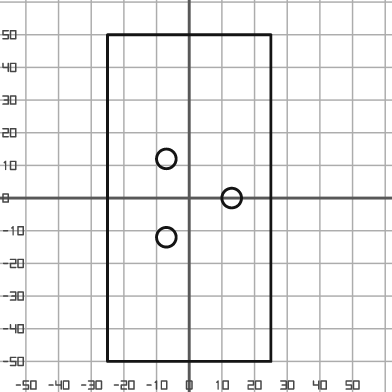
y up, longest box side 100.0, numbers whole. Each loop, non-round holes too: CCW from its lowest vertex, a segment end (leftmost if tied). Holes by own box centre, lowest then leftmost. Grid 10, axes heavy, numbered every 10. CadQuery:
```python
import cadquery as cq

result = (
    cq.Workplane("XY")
    .moveTo(-25.0, -50.0)
    .lineTo(25.0, -50.0)
    .lineTo(25.0, 50.0)
    .lineTo(-25.0, 50.0)
    .close()
    .moveTo(-7.0, -12.0)
    .circle(3.0)
    .moveTo(13.0, 0.0)
    .circle(3.0)
    .moveTo(-7.0, 12.0)
    .circle(3.0)
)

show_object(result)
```